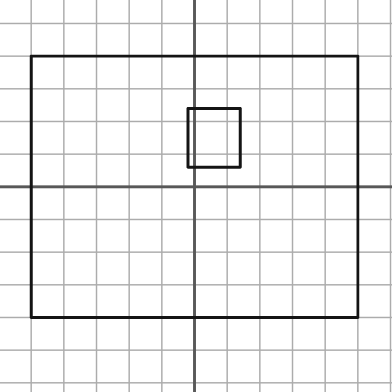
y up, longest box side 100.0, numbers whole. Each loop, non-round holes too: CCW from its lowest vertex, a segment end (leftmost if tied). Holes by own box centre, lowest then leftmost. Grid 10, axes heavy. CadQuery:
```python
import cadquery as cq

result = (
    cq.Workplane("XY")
    .moveTo(-50.0, -40.0)
    .lineTo(50.0, -40.0)
    .lineTo(50.0, 40.0)
    .lineTo(-50.0, 40.0)
    .close()
    .moveTo(-2.0, 6.0)
    .lineTo(14.0, 6.0)
    .lineTo(14.0, 24.0)
    .lineTo(-2.0, 24.0)
    .close()
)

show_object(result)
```